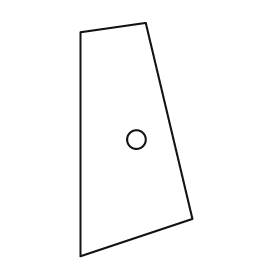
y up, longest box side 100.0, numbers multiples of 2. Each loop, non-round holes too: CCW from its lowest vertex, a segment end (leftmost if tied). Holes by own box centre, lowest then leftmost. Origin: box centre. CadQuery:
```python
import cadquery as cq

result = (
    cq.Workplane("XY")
    .moveTo(-24.0, -50.0)
    .lineTo(24.0, -34.0)
    .lineTo(4.0, 50.0)
    .lineTo(-24.0, 46.0)
    .close()
    .moveTo(0.0, 0.0)
    .circle(4.0)
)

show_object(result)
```